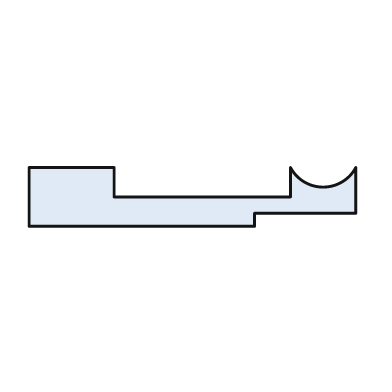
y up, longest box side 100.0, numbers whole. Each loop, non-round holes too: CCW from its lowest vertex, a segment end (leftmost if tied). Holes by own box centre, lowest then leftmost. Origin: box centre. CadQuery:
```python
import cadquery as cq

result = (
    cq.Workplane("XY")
    .moveTo(-50.0, -9.0)
    .lineTo(19.0, -9.0)
    .lineTo(19.0, -5.0)
    .lineTo(50.0, -5.0)
    .lineTo(50.0, 9.0)
    .threePointArc((40.0, 3.0), (30.0, 9.0))
    .lineTo(30.0, 0.0)
    .lineTo(-24.0, 0.0)
    .lineTo(-24.0, 9.0)
    .lineTo(-50.0, 9.0)
    .close()
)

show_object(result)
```